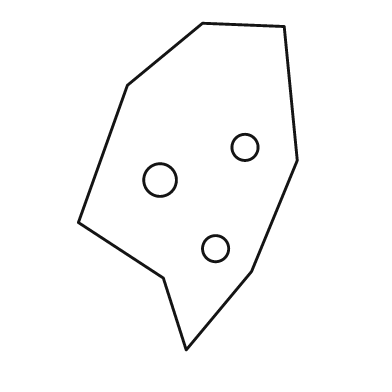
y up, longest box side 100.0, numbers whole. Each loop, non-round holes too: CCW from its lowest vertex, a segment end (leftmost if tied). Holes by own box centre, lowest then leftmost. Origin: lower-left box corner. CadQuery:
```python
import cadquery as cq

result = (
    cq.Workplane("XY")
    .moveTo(33.0, 0.0)
    .lineTo(53.0, 24.0)
    .lineTo(67.0, 58.0)
    .lineTo(63.0, 99.0)
    .lineTo(38.0, 100.0)
    .lineTo(15.0, 81.0)
    .lineTo(0.0, 39.0)
    .lineTo(26.0, 22.0)
    .close()
    .moveTo(42.0, 31.0)
    .circle(4.0)
    .moveTo(25.0, 52.0)
    .circle(5.0)
    .moveTo(51.0, 62.0)
    .circle(4.0)
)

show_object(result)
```